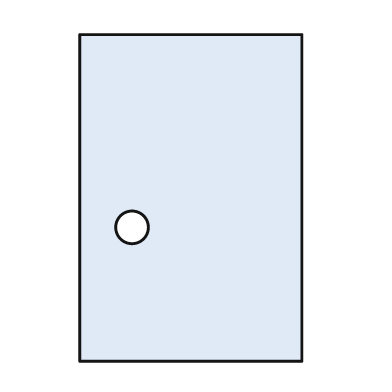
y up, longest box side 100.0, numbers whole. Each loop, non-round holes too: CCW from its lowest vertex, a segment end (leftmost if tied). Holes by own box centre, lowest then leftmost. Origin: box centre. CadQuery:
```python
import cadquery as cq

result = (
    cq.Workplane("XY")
    .moveTo(-34.0, -50.0)
    .lineTo(34.0, -50.0)
    .lineTo(34.0, 50.0)
    .lineTo(-34.0, 50.0)
    .close()
    .moveTo(-18.0, -9.0)
    .circle(5.0)
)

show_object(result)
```